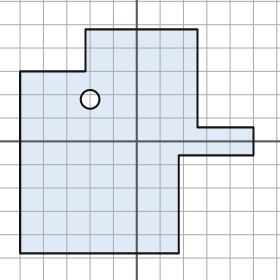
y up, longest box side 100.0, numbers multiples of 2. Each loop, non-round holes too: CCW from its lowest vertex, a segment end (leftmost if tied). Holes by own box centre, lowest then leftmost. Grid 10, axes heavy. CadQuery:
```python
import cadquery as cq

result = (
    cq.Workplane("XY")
    .moveTo(-50.0, -48.0)
    .lineTo(18.0, -48.0)
    .lineTo(18.0, -6.0)
    .lineTo(50.0, -6.0)
    .lineTo(50.0, 6.0)
    .lineTo(26.0, 6.0)
    .lineTo(26.0, 48.0)
    .lineTo(-22.0, 48.0)
    .lineTo(-22.0, 30.0)
    .lineTo(-50.0, 30.0)
    .close()
    .moveTo(-20.0, 18.0)
    .circle(4.0)
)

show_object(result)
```